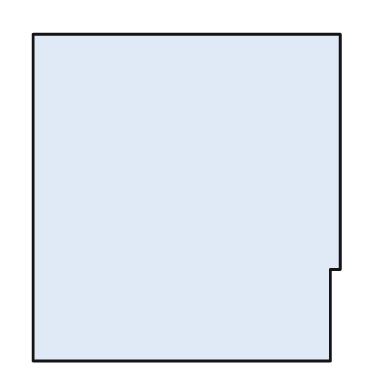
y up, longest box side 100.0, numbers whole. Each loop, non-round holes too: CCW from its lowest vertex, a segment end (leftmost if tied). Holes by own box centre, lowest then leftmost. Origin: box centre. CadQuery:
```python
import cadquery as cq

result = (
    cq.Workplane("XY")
    .moveTo(-47.0, -50.0)
    .lineTo(44.0, -50.0)
    .lineTo(44.0, -22.0)
    .lineTo(47.0, -22.0)
    .lineTo(47.0, 50.0)
    .lineTo(-47.0, 50.0)
    .close()
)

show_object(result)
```